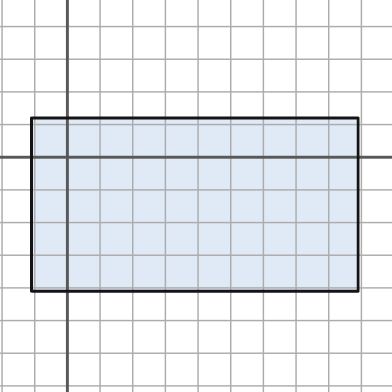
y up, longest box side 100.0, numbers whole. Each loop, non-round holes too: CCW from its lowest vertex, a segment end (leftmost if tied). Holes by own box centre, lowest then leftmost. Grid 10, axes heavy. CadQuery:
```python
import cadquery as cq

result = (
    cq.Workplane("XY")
    .moveTo(-11.0, -41.0)
    .lineTo(89.0, -41.0)
    .lineTo(89.0, 12.0)
    .lineTo(-11.0, 12.0)
    .close()
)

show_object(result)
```